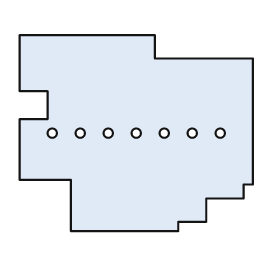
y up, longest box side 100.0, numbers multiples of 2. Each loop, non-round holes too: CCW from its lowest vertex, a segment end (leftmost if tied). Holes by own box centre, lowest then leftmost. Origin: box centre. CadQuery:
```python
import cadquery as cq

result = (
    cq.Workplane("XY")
    .moveTo(-28.0, -42.0)
    .lineTo(18.0, -42.0)
    .lineTo(18.0, -38.0)
    .lineTo(30.0, -38.0)
    .lineTo(30.0, -28.0)
    .lineTo(46.0, -28.0)
    .lineTo(46.0, -22.0)
    .lineTo(50.0, -22.0)
    .lineTo(50.0, 32.0)
    .lineTo(8.0, 32.0)
    .lineTo(8.0, 42.0)
    .lineTo(-50.0, 42.0)
    .lineTo(-50.0, 18.0)
    .lineTo(-38.0, 18.0)
    .lineTo(-38.0, 6.0)
    .lineTo(-50.0, 6.0)
    .lineTo(-50.0, -20.0)
    .lineTo(-28.0, -20.0)
    .close()
    .moveTo(-36.0, 0.0)
    .circle(2.0)
    .moveTo(-24.0, 0.0)
    .circle(2.0)
    .moveTo(-12.0, 0.0)
    .circle(2.0)
    .moveTo(0.0, 0.0)
    .circle(2.0)
    .moveTo(12.0, 0.0)
    .circle(2.0)
    .moveTo(24.0, 0.0)
    .circle(2.0)
    .moveTo(36.0, 0.0)
    .circle(2.0)
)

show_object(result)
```